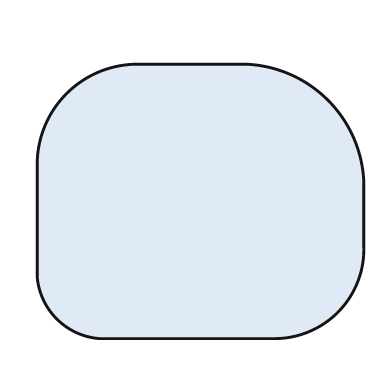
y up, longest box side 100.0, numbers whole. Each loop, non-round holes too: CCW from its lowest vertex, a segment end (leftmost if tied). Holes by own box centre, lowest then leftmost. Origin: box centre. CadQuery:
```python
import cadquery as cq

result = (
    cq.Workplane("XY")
    .moveTo(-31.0, -42.0)
    .lineTo(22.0, -42.0)
    .threePointArc((42.0, -34.0), (50.0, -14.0))
    .lineTo(50.0, 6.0)
    .threePointArc((39.0, 31.0), (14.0, 42.0))
    .lineTo(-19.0, 42.0)
    .threePointArc((-41.0, 33.0), (-50.0, 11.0))
    .lineTo(-50.0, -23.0)
    .threePointArc((-44.0, -36.0), (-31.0, -42.0))
    .close()
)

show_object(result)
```